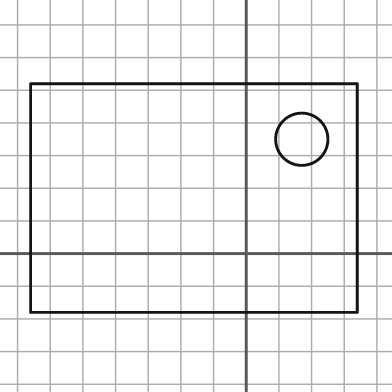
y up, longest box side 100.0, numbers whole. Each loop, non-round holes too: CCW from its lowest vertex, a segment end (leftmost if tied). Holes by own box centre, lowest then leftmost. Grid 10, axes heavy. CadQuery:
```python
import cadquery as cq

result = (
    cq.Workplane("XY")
    .moveTo(-66.0, -18.0)
    .lineTo(34.0, -18.0)
    .lineTo(34.0, 52.0)
    .lineTo(-66.0, 52.0)
    .close()
    .moveTo(17.0, 35.0)
    .circle(8.0)
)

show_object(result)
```